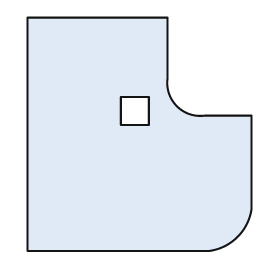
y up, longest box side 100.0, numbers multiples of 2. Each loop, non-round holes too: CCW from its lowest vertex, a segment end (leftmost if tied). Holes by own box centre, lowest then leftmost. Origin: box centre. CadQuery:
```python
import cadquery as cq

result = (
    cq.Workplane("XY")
    .moveTo(-48.0, -50.0)
    .lineTo(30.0, -50.0)
    .threePointArc((42.0, -44.0), (48.0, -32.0))
    .lineTo(48.0, 8.0)
    .lineTo(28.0, 8.0)
    .threePointArc((16.0, 12.0), (12.0, 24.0))
    .lineTo(12.0, 50.0)
    .lineTo(-48.0, 50.0)
    .close()
    .moveTo(-8.0, 4.0)
    .lineTo(4.0, 4.0)
    .lineTo(4.0, 16.0)
    .lineTo(-8.0, 16.0)
    .close()
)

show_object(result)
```